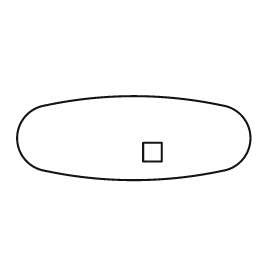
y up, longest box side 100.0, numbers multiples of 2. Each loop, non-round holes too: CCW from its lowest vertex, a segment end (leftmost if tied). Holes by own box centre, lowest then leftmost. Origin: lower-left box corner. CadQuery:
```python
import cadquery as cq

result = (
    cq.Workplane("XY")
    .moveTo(12.0, 4.0)
    .threePointArc((50.0, 0.0), (88.0, 4.0))
    .threePointArc((100.0, 18.0), (88.0, 32.0))
    .threePointArc((50.0, 36.0), (12.0, 32.0))
    .threePointArc((0.0, 18.0), (12.0, 4.0))
    .close()
    .moveTo(54.0, 8.0)
    .lineTo(62.0, 8.0)
    .lineTo(62.0, 16.0)
    .lineTo(54.0, 16.0)
    .close()
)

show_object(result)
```